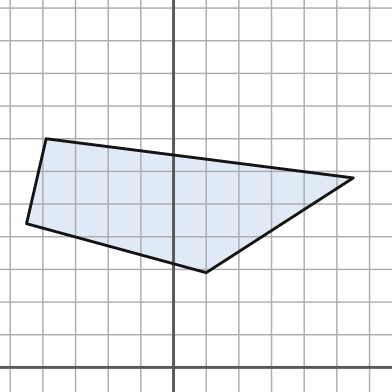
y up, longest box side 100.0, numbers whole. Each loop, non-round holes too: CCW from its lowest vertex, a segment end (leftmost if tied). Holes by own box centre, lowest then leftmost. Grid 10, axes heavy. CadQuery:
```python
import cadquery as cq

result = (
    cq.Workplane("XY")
    .moveTo(10.0, 29.0)
    .lineTo(55.0, 58.0)
    .lineTo(-39.0, 70.0)
    .lineTo(-45.0, 44.0)
    .close()
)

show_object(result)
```